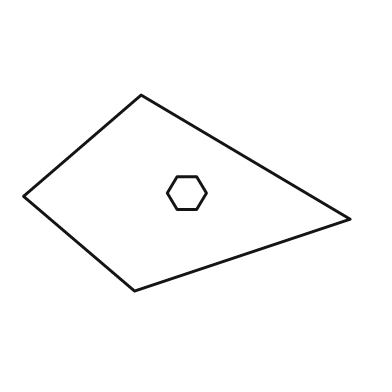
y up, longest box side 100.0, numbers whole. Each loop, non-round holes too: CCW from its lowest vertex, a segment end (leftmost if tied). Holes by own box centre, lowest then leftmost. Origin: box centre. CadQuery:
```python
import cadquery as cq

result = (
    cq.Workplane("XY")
    .moveTo(-16.0, -30.0)
    .lineTo(50.0, -8.0)
    .lineTo(-14.0, 30.0)
    .lineTo(-50.0, -1.0)
    .close()
    .moveTo(-3.0, -5.0)
    .lineTo(3.0, -5.0)
    .lineTo(6.0, 0.0)
    .lineTo(3.0, 5.0)
    .lineTo(-3.0, 5.0)
    .lineTo(-6.0, 0.0)
    .close()
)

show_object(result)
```